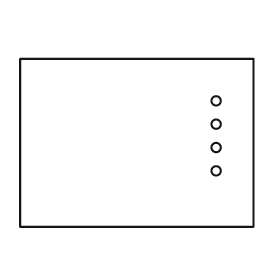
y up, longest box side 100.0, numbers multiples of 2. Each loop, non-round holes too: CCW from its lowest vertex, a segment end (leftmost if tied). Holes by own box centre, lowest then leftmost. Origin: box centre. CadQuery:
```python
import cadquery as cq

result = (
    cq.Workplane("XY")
    .moveTo(-50.0, -36.0)
    .lineTo(50.0, -36.0)
    .lineTo(50.0, 36.0)
    .lineTo(-50.0, 36.0)
    .close()
    .moveTo(34.0, -12.0)
    .circle(2.0)
    .moveTo(34.0, -2.0)
    .circle(2.0)
    .moveTo(34.0, 8.0)
    .circle(2.0)
    .moveTo(34.0, 18.0)
    .circle(2.0)
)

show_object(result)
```